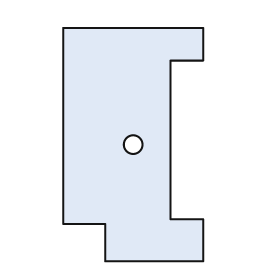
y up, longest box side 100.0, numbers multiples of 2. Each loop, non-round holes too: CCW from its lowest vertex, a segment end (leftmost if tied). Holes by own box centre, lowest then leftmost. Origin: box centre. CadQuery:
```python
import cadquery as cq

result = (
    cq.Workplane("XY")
    .moveTo(-12.0, -50.0)
    .lineTo(30.0, -50.0)
    .lineTo(30.0, -32.0)
    .lineTo(16.0, -32.0)
    .lineTo(16.0, 36.0)
    .lineTo(30.0, 36.0)
    .lineTo(30.0, 50.0)
    .lineTo(-30.0, 50.0)
    .lineTo(-30.0, -34.0)
    .lineTo(-12.0, -34.0)
    .close()
    .moveTo(0.0, 0.0)
    .circle(4.0)
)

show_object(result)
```